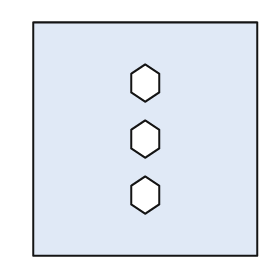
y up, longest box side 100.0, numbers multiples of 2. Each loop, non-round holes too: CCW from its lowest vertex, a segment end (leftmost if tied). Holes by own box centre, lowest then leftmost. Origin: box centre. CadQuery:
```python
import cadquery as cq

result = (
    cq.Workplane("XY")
    .moveTo(-48.0, -50.0)
    .lineTo(48.0, -50.0)
    .lineTo(48.0, 50.0)
    .lineTo(-48.0, 50.0)
    .close()
    .moveTo(0.0, -32.0)
    .lineTo(6.0, -28.0)
    .lineTo(6.0, -20.0)
    .lineTo(0.0, -16.0)
    .lineTo(-6.0, -20.0)
    .lineTo(-6.0, -28.0)
    .close()
    .moveTo(0.0, -8.0)
    .lineTo(6.0, -4.0)
    .lineTo(6.0, 4.0)
    .lineTo(0.0, 8.0)
    .lineTo(-6.0, 4.0)
    .lineTo(-6.0, -4.0)
    .close()
    .moveTo(0.0, 16.0)
    .lineTo(6.0, 20.0)
    .lineTo(6.0, 28.0)
    .lineTo(0.0, 32.0)
    .lineTo(-6.0, 28.0)
    .lineTo(-6.0, 20.0)
    .close()
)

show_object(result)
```